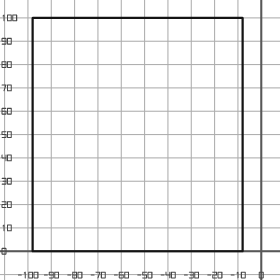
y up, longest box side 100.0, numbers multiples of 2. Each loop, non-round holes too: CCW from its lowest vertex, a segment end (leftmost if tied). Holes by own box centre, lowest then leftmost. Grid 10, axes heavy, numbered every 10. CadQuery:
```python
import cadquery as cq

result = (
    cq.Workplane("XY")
    .moveTo(-98.0, 0.0)
    .lineTo(-8.0, 0.0)
    .lineTo(-8.0, 100.0)
    .lineTo(-98.0, 100.0)
    .close()
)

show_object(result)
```